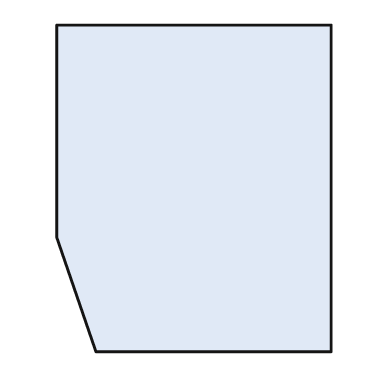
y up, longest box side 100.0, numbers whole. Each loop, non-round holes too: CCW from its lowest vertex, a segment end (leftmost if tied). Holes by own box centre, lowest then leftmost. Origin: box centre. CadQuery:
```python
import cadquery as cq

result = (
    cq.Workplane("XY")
    .moveTo(-30.0, -50.0)
    .lineTo(42.0, -50.0)
    .lineTo(42.0, 50.0)
    .lineTo(-42.0, 50.0)
    .lineTo(-42.0, -15.0)
    .close()
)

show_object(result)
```